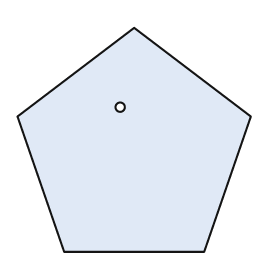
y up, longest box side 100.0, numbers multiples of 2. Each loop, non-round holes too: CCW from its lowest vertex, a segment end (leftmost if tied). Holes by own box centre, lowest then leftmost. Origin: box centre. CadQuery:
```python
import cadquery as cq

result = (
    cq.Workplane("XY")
    .moveTo(-30.0, -48.0)
    .lineTo(30.0, -48.0)
    .lineTo(50.0, 10.0)
    .lineTo(0.0, 48.0)
    .lineTo(-50.0, 10.0)
    .close()
    .moveTo(-6.0, 14.0)
    .circle(2.0)
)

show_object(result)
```